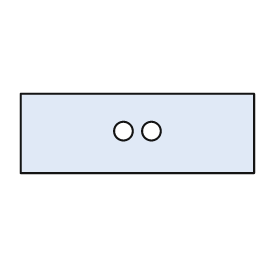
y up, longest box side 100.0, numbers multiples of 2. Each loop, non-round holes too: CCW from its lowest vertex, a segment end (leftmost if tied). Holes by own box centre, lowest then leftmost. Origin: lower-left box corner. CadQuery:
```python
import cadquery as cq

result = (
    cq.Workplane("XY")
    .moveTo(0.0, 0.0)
    .lineTo(100.0, 0.0)
    .lineTo(100.0, 34.0)
    .lineTo(0.0, 34.0)
    .close()
    .moveTo(44.0, 18.0)
    .circle(4.0)
    .moveTo(56.0, 18.0)
    .circle(4.0)
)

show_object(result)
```